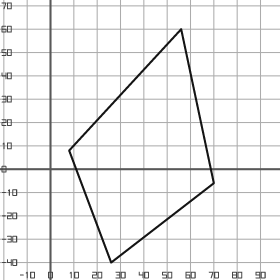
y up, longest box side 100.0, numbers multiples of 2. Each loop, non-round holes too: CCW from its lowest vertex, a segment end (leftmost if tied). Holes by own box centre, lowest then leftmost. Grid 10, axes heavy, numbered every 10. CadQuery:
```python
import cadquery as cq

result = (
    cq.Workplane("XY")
    .moveTo(26.0, -40.0)
    .lineTo(70.0, -6.0)
    .lineTo(56.0, 60.0)
    .lineTo(8.0, 8.0)
    .close()
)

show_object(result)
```